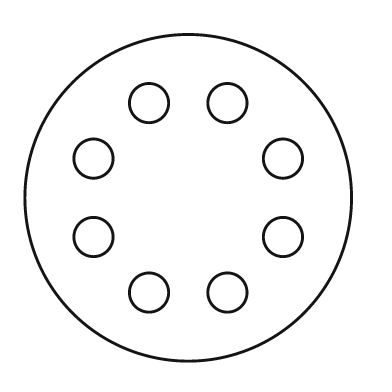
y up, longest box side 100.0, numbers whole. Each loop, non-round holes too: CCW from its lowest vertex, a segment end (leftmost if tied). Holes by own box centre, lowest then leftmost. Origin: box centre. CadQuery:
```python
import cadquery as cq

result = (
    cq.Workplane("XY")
    .moveTo(0.0, 0.0)
    .circle(50.0)
    .moveTo(-12.0, -29.0)
    .circle(6.0)
    .moveTo(12.0, -29.0)
    .circle(6.0)
    .moveTo(-29.0, -12.0)
    .circle(6.0)
    .moveTo(29.0, -12.0)
    .circle(6.0)
    .moveTo(-29.0, 12.0)
    .circle(6.0)
    .moveTo(29.0, 12.0)
    .circle(6.0)
    .moveTo(-12.0, 29.0)
    .circle(6.0)
    .moveTo(12.0, 29.0)
    .circle(6.0)
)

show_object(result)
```